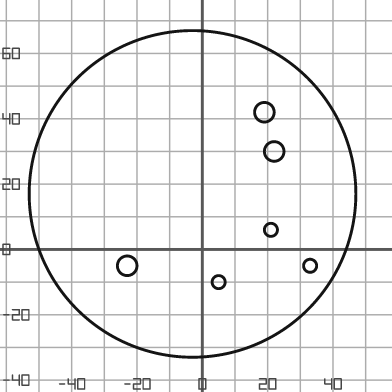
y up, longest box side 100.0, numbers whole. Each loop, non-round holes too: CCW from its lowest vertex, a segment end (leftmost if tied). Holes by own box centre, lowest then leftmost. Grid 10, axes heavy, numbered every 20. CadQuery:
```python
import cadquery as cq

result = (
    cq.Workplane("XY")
    .moveTo(-3.0, 17.0)
    .circle(50.0)
    .moveTo(5.0, -10.0)
    .circle(2.0)
    .moveTo(-23.0, -5.0)
    .circle(3.0)
    .moveTo(33.0, -5.0)
    .circle(2.0)
    .moveTo(21.0, 6.0)
    .circle(2.0)
    .moveTo(22.0, 30.0)
    .circle(3.0)
    .moveTo(19.0, 42.0)
    .circle(3.0)
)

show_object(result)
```